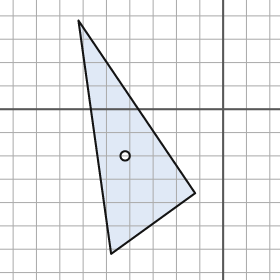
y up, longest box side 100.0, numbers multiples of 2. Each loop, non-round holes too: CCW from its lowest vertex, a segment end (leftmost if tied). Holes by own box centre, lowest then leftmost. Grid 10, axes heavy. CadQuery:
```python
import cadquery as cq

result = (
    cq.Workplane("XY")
    .moveTo(-48.0, -62.0)
    .lineTo(-12.0, -36.0)
    .lineTo(-62.0, 38.0)
    .close()
    .moveTo(-42.0, -20.0)
    .circle(2.0)
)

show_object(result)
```